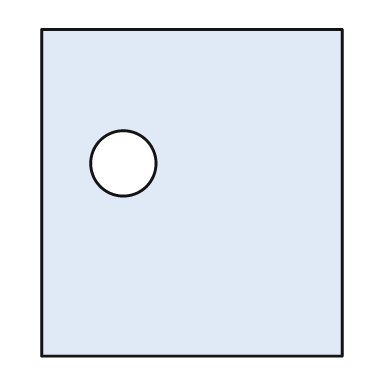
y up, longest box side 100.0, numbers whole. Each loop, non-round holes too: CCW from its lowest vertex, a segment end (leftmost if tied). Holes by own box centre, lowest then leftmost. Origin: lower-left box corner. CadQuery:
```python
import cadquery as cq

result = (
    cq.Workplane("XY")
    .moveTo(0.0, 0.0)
    .lineTo(92.0, 0.0)
    .lineTo(92.0, 100.0)
    .lineTo(0.0, 100.0)
    .close()
    .moveTo(25.0, 59.0)
    .circle(10.0)
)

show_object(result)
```